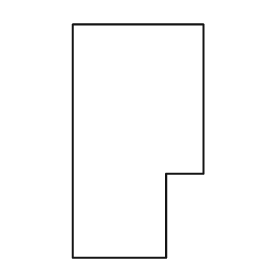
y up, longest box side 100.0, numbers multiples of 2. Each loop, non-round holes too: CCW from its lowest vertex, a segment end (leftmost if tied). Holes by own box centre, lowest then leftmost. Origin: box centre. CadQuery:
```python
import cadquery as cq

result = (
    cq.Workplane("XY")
    .moveTo(-28.0, -50.0)
    .lineTo(12.0, -50.0)
    .lineTo(12.0, -14.0)
    .lineTo(28.0, -14.0)
    .lineTo(28.0, 50.0)
    .lineTo(-28.0, 50.0)
    .close()
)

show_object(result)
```